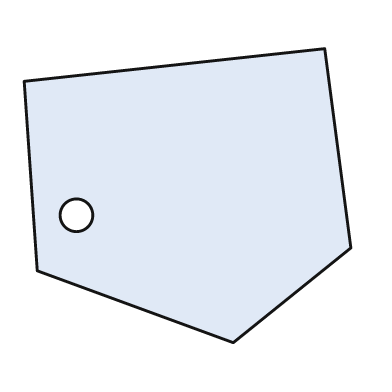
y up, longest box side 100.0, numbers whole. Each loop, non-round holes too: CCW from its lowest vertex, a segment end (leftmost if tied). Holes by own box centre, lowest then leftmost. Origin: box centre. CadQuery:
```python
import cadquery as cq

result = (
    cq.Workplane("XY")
    .moveTo(14.0, -45.0)
    .lineTo(50.0, -16.0)
    .lineTo(42.0, 45.0)
    .lineTo(-50.0, 35.0)
    .lineTo(-46.0, -23.0)
    .close()
    .moveTo(-34.0, -6.0)
    .circle(5.0)
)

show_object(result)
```